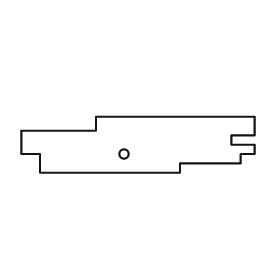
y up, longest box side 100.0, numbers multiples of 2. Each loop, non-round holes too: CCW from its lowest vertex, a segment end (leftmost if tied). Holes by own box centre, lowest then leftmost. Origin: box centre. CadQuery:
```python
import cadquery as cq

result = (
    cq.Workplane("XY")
    .moveTo(-42.0, -12.0)
    .lineTo(18.0, -12.0)
    .lineTo(18.0, -8.0)
    .lineTo(44.0, -8.0)
    .lineTo(44.0, -4.0)
    .lineTo(50.0, -4.0)
    .lineTo(50.0, 0.0)
    .lineTo(40.0, 0.0)
    .lineTo(40.0, 4.0)
    .lineTo(50.0, 4.0)
    .lineTo(50.0, 12.0)
    .lineTo(-18.0, 12.0)
    .lineTo(-18.0, 6.0)
    .lineTo(-50.0, 6.0)
    .lineTo(-50.0, -4.0)
    .lineTo(-42.0, -4.0)
    .close()
    .moveTo(-6.0, -4.0)
    .circle(2.0)
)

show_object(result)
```